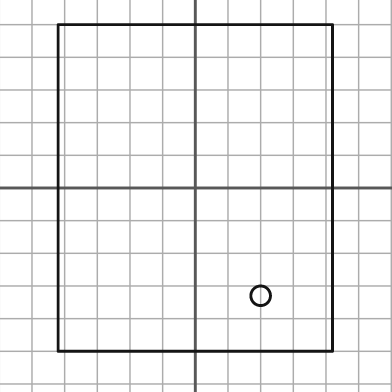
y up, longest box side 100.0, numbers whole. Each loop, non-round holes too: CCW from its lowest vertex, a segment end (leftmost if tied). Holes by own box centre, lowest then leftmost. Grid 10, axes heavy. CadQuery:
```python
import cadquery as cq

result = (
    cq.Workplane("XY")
    .moveTo(-42.0, -50.0)
    .lineTo(42.0, -50.0)
    .lineTo(42.0, 50.0)
    .lineTo(-42.0, 50.0)
    .close()
    .moveTo(20.0, -33.0)
    .circle(3.0)
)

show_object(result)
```